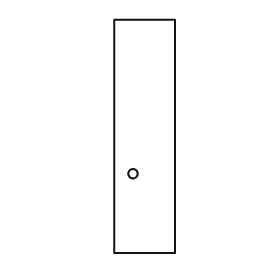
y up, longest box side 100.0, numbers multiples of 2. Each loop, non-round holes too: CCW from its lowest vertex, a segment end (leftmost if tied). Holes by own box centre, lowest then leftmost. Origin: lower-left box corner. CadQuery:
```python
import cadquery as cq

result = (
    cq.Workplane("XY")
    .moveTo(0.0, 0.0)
    .lineTo(26.0, 0.0)
    .lineTo(26.0, 100.0)
    .lineTo(0.0, 100.0)
    .close()
    .moveTo(8.0, 34.0)
    .circle(2.0)
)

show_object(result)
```